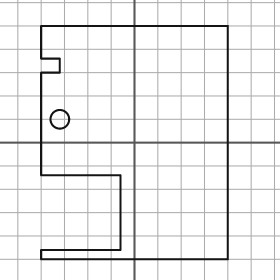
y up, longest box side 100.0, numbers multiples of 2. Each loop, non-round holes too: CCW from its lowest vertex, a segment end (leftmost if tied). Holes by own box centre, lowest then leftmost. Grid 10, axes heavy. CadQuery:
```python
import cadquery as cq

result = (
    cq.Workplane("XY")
    .moveTo(-40.0, -50.0)
    .lineTo(40.0, -50.0)
    .lineTo(40.0, 50.0)
    .lineTo(-40.0, 50.0)
    .lineTo(-40.0, 36.0)
    .lineTo(-32.0, 36.0)
    .lineTo(-32.0, 30.0)
    .lineTo(-40.0, 30.0)
    .lineTo(-40.0, -14.0)
    .lineTo(-6.0, -14.0)
    .lineTo(-6.0, -46.0)
    .lineTo(-40.0, -46.0)
    .close()
    .moveTo(-32.0, 10.0)
    .circle(4.0)
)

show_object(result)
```